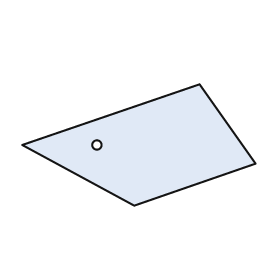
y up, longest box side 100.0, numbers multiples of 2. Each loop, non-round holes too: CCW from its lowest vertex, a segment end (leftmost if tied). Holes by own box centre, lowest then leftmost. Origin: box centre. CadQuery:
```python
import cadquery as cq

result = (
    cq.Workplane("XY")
    .moveTo(-2.0, -26.0)
    .lineTo(50.0, -8.0)
    .lineTo(26.0, 26.0)
    .lineTo(-50.0, 0.0)
    .close()
    .moveTo(-18.0, 0.0)
    .circle(2.0)
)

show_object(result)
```